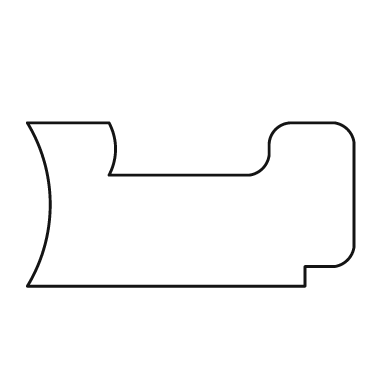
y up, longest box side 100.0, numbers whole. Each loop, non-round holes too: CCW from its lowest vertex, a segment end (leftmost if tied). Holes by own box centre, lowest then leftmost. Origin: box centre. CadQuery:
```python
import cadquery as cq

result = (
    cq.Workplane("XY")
    .moveTo(-50.0, -25.0)
    .lineTo(35.0, -25.0)
    .lineTo(35.0, -19.0)
    .lineTo(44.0, -19.0)
    .threePointArc((48.0, -17.0), (50.0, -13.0))
    .lineTo(50.0, 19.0)
    .threePointArc((48.0, 23.0), (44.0, 25.0))
    .lineTo(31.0, 25.0)
    .threePointArc((26.0, 23.0), (24.0, 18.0))
    .lineTo(24.0, 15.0)
    .threePointArc((22.0, 11.0), (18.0, 9.0))
    .lineTo(-25.0, 9.0)
    .threePointArc((-23.0, 17.0), (-25.0, 25.0))
    .lineTo(-50.0, 25.0)
    .threePointArc((-43.0, 0.0), (-50.0, -25.0))
    .close()
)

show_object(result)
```